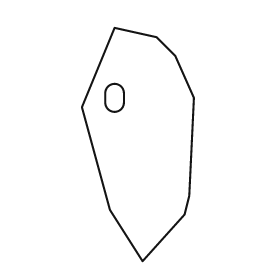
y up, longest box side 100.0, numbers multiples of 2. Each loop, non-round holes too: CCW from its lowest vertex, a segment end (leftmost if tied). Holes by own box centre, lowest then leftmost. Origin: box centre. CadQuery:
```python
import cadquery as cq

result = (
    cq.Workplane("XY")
    .moveTo(2.0, -50.0)
    .lineTo(20.0, -30.0)
    .lineTo(22.0, -22.0)
    .lineTo(24.0, 20.0)
    .lineTo(16.0, 38.0)
    .lineTo(8.0, 46.0)
    .lineTo(-10.0, 50.0)
    .lineTo(-24.0, 16.0)
    .lineTo(-12.0, -28.0)
    .close()
    .moveTo(-14.0, 18.0)
    .threePointArc((-10.0, 14.0), (-6.0, 18.0))
    .lineTo(-6.0, 22.0)
    .threePointArc((-10.0, 26.0), (-14.0, 22.0))
    .close()
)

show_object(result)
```